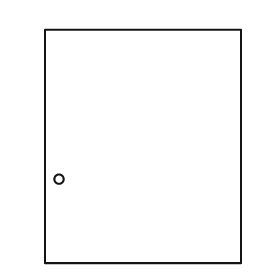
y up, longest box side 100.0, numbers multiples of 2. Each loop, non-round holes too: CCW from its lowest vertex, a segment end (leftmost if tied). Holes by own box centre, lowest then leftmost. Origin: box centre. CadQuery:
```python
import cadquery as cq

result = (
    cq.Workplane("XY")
    .moveTo(-42.0, -50.0)
    .lineTo(42.0, -50.0)
    .lineTo(42.0, 50.0)
    .lineTo(-42.0, 50.0)
    .close()
    .moveTo(-36.0, -14.0)
    .circle(2.0)
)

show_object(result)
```